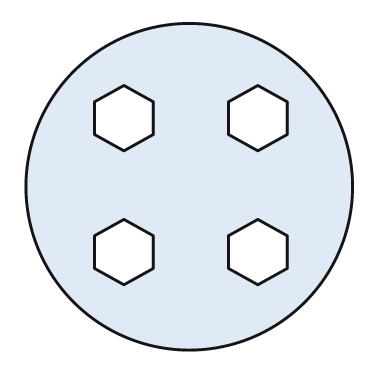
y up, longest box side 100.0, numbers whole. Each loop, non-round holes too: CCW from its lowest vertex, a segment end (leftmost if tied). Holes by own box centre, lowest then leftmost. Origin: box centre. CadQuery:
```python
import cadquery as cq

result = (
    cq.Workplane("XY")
    .moveTo(0.0, 0.0)
    .circle(50.0)
    .moveTo(-20.0, -30.0)
    .lineTo(-11.0, -25.0)
    .lineTo(-11.0, -15.0)
    .lineTo(-20.0, -10.0)
    .lineTo(-29.0, -15.0)
    .lineTo(-29.0, -25.0)
    .close()
    .moveTo(21.0, -30.0)
    .lineTo(30.0, -25.0)
    .lineTo(30.0, -15.0)
    .lineTo(21.0, -10.0)
    .lineTo(12.0, -15.0)
    .lineTo(12.0, -25.0)
    .close()
    .moveTo(-20.0, 11.0)
    .lineTo(-11.0, 16.0)
    .lineTo(-11.0, 26.0)
    .lineTo(-20.0, 31.0)
    .lineTo(-29.0, 26.0)
    .lineTo(-29.0, 16.0)
    .close()
    .moveTo(21.0, 11.0)
    .lineTo(30.0, 16.0)
    .lineTo(30.0, 26.0)
    .lineTo(21.0, 31.0)
    .lineTo(12.0, 26.0)
    .lineTo(12.0, 16.0)
    .close()
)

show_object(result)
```